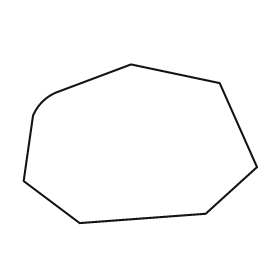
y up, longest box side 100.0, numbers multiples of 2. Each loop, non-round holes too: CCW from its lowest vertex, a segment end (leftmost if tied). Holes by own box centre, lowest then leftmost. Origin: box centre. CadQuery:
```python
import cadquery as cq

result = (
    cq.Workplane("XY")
    .moveTo(-26.0, -34.0)
    .lineTo(28.0, -30.0)
    .lineTo(50.0, -10.0)
    .lineTo(34.0, 26.0)
    .lineTo(-4.0, 34.0)
    .lineTo(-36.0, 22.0)
    .threePointArc((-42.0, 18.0), (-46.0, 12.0))
    .lineTo(-50.0, -16.0)
    .close()
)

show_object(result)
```